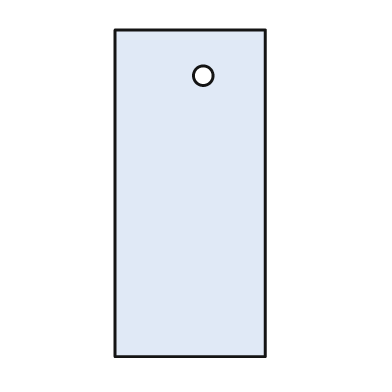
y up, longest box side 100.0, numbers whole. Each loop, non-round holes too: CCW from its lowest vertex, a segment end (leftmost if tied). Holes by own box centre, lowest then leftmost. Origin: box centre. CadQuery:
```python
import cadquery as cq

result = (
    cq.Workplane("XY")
    .moveTo(-23.0, -50.0)
    .lineTo(23.0, -50.0)
    .lineTo(23.0, 50.0)
    .lineTo(-23.0, 50.0)
    .close()
    .moveTo(4.0, 36.0)
    .circle(3.0)
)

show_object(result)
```